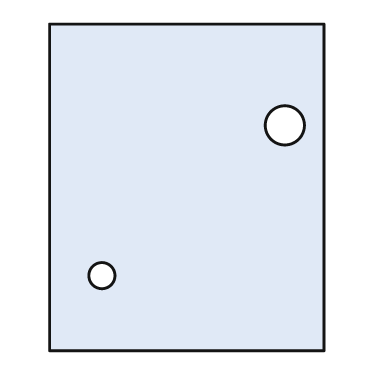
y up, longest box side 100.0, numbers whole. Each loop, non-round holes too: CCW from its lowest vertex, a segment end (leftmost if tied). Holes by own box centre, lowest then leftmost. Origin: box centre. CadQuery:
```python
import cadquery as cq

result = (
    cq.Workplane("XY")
    .moveTo(-42.0, -50.0)
    .lineTo(42.0, -50.0)
    .lineTo(42.0, 50.0)
    .lineTo(-42.0, 50.0)
    .close()
    .moveTo(-26.0, -27.0)
    .circle(4.0)
    .moveTo(30.0, 19.0)
    .circle(6.0)
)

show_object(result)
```